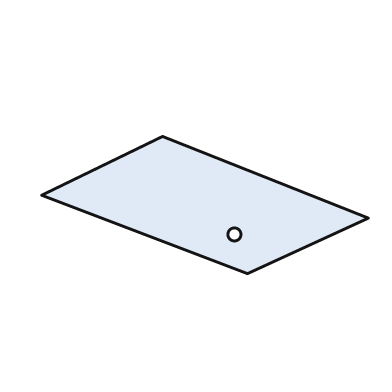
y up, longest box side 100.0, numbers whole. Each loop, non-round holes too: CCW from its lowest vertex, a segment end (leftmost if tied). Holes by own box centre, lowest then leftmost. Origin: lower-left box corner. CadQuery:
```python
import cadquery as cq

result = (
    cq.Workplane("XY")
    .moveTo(63.0, 0.0)
    .lineTo(100.0, 17.0)
    .lineTo(37.0, 42.0)
    .lineTo(0.0, 24.0)
    .close()
    .moveTo(59.0, 12.0)
    .circle(2.0)
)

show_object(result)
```